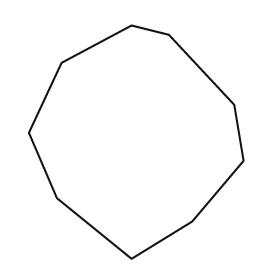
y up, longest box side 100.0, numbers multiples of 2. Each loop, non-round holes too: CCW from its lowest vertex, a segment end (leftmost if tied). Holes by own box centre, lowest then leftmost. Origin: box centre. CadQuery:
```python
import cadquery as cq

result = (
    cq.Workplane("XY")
    .moveTo(-2.0, -50.0)
    .lineTo(24.0, -34.0)
    .lineTo(46.0, -8.0)
    .lineTo(42.0, 16.0)
    .lineTo(14.0, 46.0)
    .lineTo(-2.0, 50.0)
    .lineTo(-32.0, 34.0)
    .lineTo(-46.0, 4.0)
    .lineTo(-34.0, -24.0)
    .close()
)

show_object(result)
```